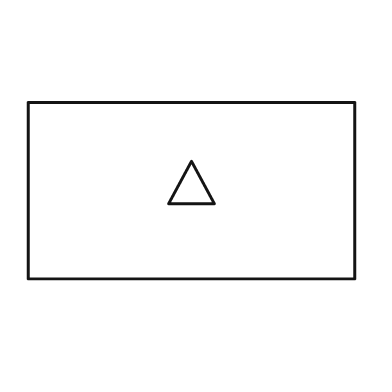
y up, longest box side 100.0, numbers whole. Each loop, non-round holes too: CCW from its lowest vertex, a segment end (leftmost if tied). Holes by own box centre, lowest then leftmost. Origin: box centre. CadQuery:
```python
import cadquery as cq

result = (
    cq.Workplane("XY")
    .moveTo(-50.0, -27.0)
    .lineTo(50.0, -27.0)
    .lineTo(50.0, 27.0)
    .lineTo(-50.0, 27.0)
    .close()
    .moveTo(-7.0, -4.0)
    .lineTo(7.0, -4.0)
    .lineTo(0.0, 9.0)
    .close()
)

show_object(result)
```